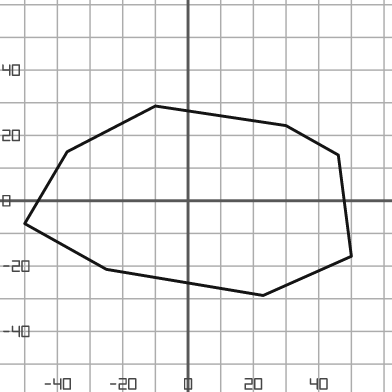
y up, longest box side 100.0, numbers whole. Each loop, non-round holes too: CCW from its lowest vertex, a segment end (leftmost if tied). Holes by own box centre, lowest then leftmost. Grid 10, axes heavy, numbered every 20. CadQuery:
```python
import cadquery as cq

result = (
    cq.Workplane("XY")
    .moveTo(23.0, -29.0)
    .lineTo(50.0, -17.0)
    .lineTo(46.0, 14.0)
    .lineTo(30.0, 23.0)
    .lineTo(-10.0, 29.0)
    .lineTo(-37.0, 15.0)
    .lineTo(-50.0, -7.0)
    .lineTo(-25.0, -21.0)
    .close()
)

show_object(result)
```